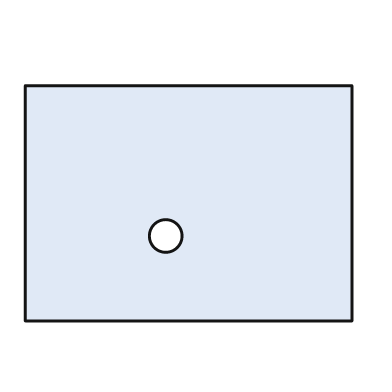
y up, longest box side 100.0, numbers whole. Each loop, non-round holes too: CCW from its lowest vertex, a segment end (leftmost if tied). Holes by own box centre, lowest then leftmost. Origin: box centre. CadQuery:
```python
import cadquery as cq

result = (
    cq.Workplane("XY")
    .moveTo(-50.0, -36.0)
    .lineTo(50.0, -36.0)
    .lineTo(50.0, 36.0)
    .lineTo(-50.0, 36.0)
    .close()
    .moveTo(-7.0, -10.0)
    .circle(5.0)
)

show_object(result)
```